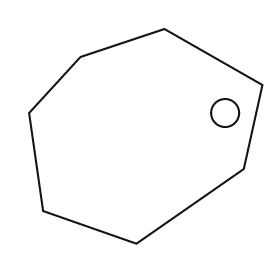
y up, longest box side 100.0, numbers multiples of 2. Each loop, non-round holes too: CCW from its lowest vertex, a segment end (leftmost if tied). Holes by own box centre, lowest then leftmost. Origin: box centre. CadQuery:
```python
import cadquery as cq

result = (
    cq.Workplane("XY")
    .moveTo(-4.0, -46.0)
    .lineTo(42.0, -14.0)
    .lineTo(50.0, 22.0)
    .lineTo(8.0, 46.0)
    .lineTo(-28.0, 34.0)
    .lineTo(-50.0, 10.0)
    .lineTo(-44.0, -32.0)
    .close()
    .moveTo(34.0, 10.0)
    .circle(6.0)
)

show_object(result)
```